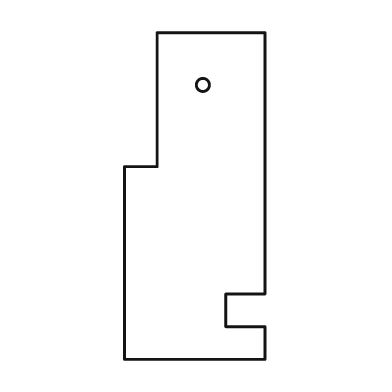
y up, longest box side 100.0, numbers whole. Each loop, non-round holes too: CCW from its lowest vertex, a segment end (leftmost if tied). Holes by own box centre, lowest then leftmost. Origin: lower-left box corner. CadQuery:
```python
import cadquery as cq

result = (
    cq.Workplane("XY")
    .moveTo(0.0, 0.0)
    .lineTo(43.0, 0.0)
    .lineTo(43.0, 10.0)
    .lineTo(31.0, 10.0)
    .lineTo(31.0, 20.0)
    .lineTo(43.0, 20.0)
    .lineTo(43.0, 100.0)
    .lineTo(10.0, 100.0)
    .lineTo(10.0, 59.0)
    .lineTo(0.0, 59.0)
    .close()
    .moveTo(24.0, 84.0)
    .circle(2.0)
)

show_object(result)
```